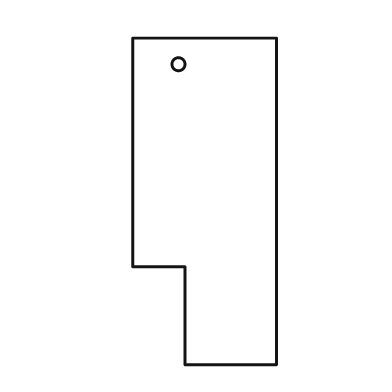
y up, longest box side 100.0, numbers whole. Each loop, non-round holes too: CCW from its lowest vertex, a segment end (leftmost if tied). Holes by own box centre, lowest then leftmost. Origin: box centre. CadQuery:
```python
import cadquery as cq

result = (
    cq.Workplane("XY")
    .moveTo(-6.0, -50.0)
    .lineTo(22.0, -50.0)
    .lineTo(22.0, 50.0)
    .lineTo(-22.0, 50.0)
    .lineTo(-22.0, -20.0)
    .lineTo(-6.0, -20.0)
    .close()
    .moveTo(-8.0, 42.0)
    .circle(2.0)
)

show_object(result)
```